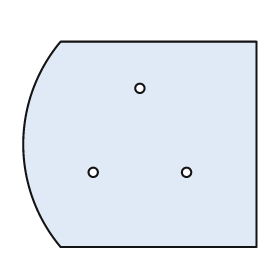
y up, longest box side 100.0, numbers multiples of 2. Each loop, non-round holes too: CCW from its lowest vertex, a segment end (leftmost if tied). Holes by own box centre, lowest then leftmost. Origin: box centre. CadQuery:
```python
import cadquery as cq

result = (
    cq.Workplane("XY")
    .moveTo(-34.0, -44.0)
    .lineTo(50.0, -44.0)
    .lineTo(50.0, 44.0)
    .lineTo(-34.0, 44.0)
    .threePointArc((-50.0, 0.0), (-34.0, -44.0))
    .close()
    .moveTo(-20.0, -12.0)
    .circle(2.0)
    .moveTo(20.0, -12.0)
    .circle(2.0)
    .moveTo(0.0, 24.0)
    .circle(2.0)
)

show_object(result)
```